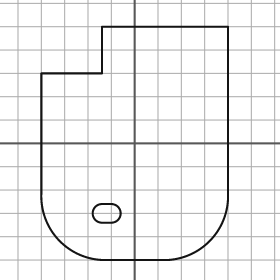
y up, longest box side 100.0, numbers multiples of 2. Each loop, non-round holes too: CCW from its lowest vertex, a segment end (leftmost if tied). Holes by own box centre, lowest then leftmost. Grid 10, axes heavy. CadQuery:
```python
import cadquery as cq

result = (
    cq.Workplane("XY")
    .moveTo(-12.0, -50.0)
    .lineTo(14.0, -50.0)
    .threePointArc((32.0, -42.0), (40.0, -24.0))
    .lineTo(40.0, 50.0)
    .lineTo(-14.0, 50.0)
    .lineTo(-14.0, 30.0)
    .lineTo(-40.0, 30.0)
    .lineTo(-40.0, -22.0)
    .threePointArc((-32.0, -42.0), (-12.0, -50.0))
    .close()
    .moveTo(-14.0, -34.0)
    .lineTo(-10.0, -34.0)
    .threePointArc((-6.0, -30.0), (-10.0, -26.0))
    .lineTo(-14.0, -26.0)
    .threePointArc((-18.0, -30.0), (-14.0, -34.0))
    .close()
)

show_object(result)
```